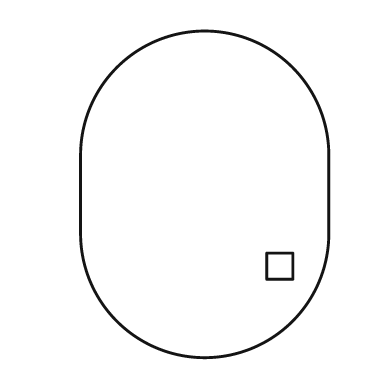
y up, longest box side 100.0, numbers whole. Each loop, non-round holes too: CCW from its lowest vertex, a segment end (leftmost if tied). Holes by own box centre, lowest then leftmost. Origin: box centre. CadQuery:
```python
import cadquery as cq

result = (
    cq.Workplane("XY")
    .moveTo(-38.0, -12.0)
    .threePointArc((0.0, -50.0), (38.0, -12.0))
    .lineTo(38.0, 12.0)
    .threePointArc((0.0, 50.0), (-38.0, 12.0))
    .close()
    .moveTo(19.0, -26.0)
    .lineTo(27.0, -26.0)
    .lineTo(27.0, -18.0)
    .lineTo(19.0, -18.0)
    .close()
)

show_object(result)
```